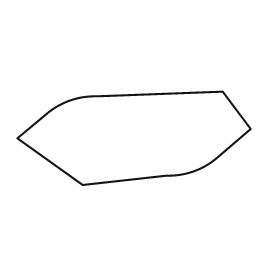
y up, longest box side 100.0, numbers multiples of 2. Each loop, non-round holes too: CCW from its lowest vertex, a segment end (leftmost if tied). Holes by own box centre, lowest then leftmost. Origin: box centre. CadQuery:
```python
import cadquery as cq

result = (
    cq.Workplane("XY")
    .moveTo(-22.0, -20.0)
    .lineTo(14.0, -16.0)
    .threePointArc((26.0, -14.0), (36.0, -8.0))
    .lineTo(50.0, 4.0)
    .lineTo(38.0, 20.0)
    .lineTo(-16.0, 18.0)
    .threePointArc((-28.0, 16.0), (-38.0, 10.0))
    .lineTo(-50.0, 0.0)
    .close()
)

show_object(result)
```